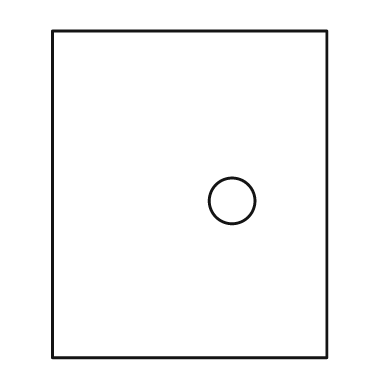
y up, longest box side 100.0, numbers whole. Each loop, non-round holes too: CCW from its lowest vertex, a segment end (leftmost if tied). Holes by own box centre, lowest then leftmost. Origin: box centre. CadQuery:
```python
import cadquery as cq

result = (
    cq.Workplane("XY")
    .moveTo(-42.0, -50.0)
    .lineTo(42.0, -50.0)
    .lineTo(42.0, 50.0)
    .lineTo(-42.0, 50.0)
    .close()
    .moveTo(13.0, -2.0)
    .circle(7.0)
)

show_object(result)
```